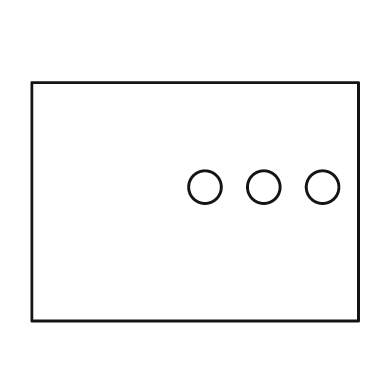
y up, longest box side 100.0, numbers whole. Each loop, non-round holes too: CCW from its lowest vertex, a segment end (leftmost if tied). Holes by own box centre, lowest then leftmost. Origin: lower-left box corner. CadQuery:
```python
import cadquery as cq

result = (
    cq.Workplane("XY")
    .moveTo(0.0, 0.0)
    .lineTo(100.0, 0.0)
    .lineTo(100.0, 73.0)
    .lineTo(0.0, 73.0)
    .close()
    .moveTo(53.0, 41.0)
    .circle(5.0)
    .moveTo(71.0, 41.0)
    .circle(5.0)
    .moveTo(89.0, 41.0)
    .circle(5.0)
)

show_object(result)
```